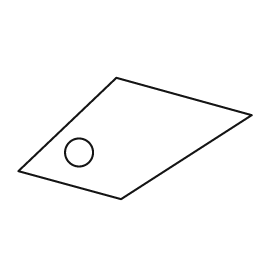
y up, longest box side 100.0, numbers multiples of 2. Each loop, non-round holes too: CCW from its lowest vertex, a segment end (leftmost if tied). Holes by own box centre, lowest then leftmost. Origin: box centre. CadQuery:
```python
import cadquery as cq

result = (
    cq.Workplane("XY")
    .moveTo(-6.0, -26.0)
    .lineTo(50.0, 10.0)
    .lineTo(-8.0, 26.0)
    .lineTo(-50.0, -14.0)
    .close()
    .moveTo(-24.0, -6.0)
    .circle(6.0)
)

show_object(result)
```